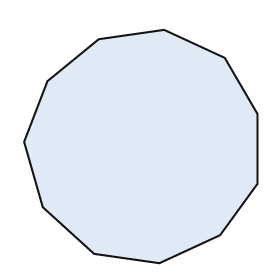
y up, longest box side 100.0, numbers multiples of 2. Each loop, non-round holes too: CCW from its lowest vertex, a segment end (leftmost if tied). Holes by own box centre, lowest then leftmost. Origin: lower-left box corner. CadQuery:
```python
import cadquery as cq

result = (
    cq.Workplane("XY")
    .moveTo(58.0, 0.0)
    .lineTo(84.0, 12.0)
    .lineTo(100.0, 34.0)
    .lineTo(100.0, 64.0)
    .lineTo(86.0, 88.0)
    .lineTo(60.0, 100.0)
    .lineTo(32.0, 96.0)
    .lineTo(10.0, 78.0)
    .lineTo(0.0, 52.0)
    .lineTo(8.0, 24.0)
    .lineTo(30.0, 4.0)
    .close()
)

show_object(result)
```